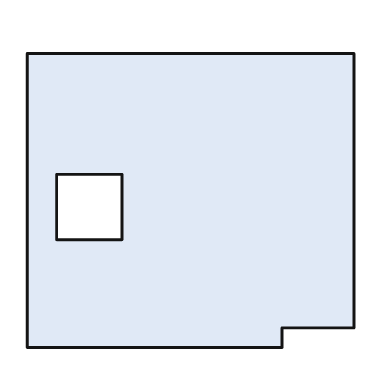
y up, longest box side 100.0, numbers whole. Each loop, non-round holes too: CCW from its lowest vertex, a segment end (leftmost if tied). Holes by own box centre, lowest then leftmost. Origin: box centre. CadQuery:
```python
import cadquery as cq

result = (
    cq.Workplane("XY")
    .moveTo(-50.0, -45.0)
    .lineTo(28.0, -45.0)
    .lineTo(28.0, -39.0)
    .lineTo(50.0, -39.0)
    .lineTo(50.0, 45.0)
    .lineTo(-50.0, 45.0)
    .close()
    .moveTo(-41.0, -12.0)
    .lineTo(-21.0, -12.0)
    .lineTo(-21.0, 8.0)
    .lineTo(-41.0, 8.0)
    .close()
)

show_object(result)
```